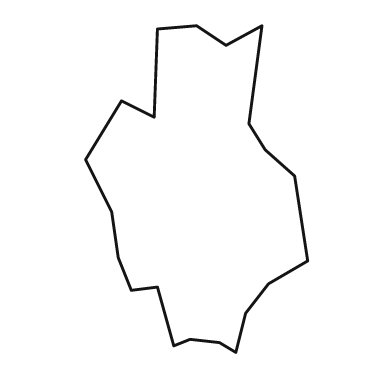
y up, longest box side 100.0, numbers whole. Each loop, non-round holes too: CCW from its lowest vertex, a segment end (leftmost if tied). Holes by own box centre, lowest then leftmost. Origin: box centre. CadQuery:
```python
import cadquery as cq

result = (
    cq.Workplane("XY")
    .moveTo(12.0, -50.0)
    .lineTo(15.0, -38.0)
    .lineTo(22.0, -29.0)
    .lineTo(34.0, -22.0)
    .lineTo(30.0, 4.0)
    .lineTo(21.0, 12.0)
    .lineTo(16.0, 20.0)
    .lineTo(20.0, 50.0)
    .lineTo(9.0, 44.0)
    .lineTo(0.0, 50.0)
    .lineTo(-12.0, 49.0)
    .lineTo(-13.0, 22.0)
    .lineTo(-23.0, 27.0)
    .lineTo(-34.0, 9.0)
    .lineTo(-26.0, -7.0)
    .lineTo(-24.0, -21.0)
    .lineTo(-20.0, -31.0)
    .lineTo(-12.0, -30.0)
    .lineTo(-7.0, -48.0)
    .lineTo(-2.0, -46.0)
    .lineTo(7.0, -47.0)
    .close()
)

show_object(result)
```